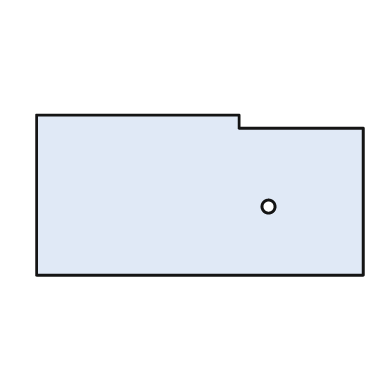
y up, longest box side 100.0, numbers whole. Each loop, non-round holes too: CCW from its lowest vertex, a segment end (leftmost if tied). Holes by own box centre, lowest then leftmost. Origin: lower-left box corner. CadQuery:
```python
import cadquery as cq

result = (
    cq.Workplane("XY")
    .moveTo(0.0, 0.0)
    .lineTo(100.0, 0.0)
    .lineTo(100.0, 45.0)
    .lineTo(62.0, 45.0)
    .lineTo(62.0, 49.0)
    .lineTo(0.0, 49.0)
    .close()
    .moveTo(71.0, 21.0)
    .circle(2.0)
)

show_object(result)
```